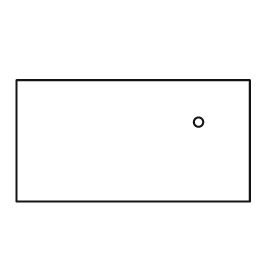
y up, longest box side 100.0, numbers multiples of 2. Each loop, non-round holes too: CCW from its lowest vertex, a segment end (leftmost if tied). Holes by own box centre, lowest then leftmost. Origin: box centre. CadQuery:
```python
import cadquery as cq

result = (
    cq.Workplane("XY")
    .moveTo(-50.0, -26.0)
    .lineTo(50.0, -26.0)
    .lineTo(50.0, 26.0)
    .lineTo(-50.0, 26.0)
    .close()
    .moveTo(28.0, 8.0)
    .circle(2.0)
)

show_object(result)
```